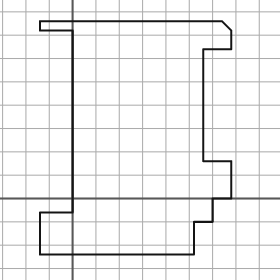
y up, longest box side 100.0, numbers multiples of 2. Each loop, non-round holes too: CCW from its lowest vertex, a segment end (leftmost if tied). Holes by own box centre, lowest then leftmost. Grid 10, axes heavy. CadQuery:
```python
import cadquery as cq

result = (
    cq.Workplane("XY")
    .moveTo(-14.0, -24.0)
    .lineTo(52.0, -24.0)
    .lineTo(52.0, -10.0)
    .lineTo(60.0, -10.0)
    .lineTo(60.0, 0.0)
    .lineTo(68.0, 0.0)
    .lineTo(68.0, 16.0)
    .lineTo(56.0, 16.0)
    .lineTo(56.0, 64.0)
    .lineTo(68.0, 64.0)
    .lineTo(68.0, 72.0)
    .lineTo(64.0, 76.0)
    .lineTo(-14.0, 76.0)
    .lineTo(-14.0, 72.0)
    .lineTo(0.0, 72.0)
    .lineTo(0.0, -6.0)
    .lineTo(-14.0, -6.0)
    .close()
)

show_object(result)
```